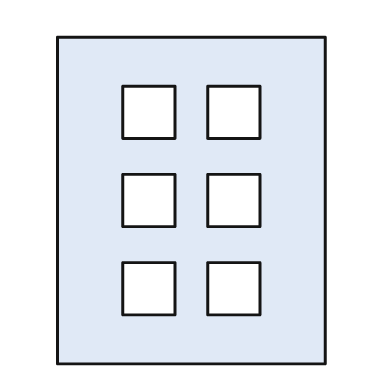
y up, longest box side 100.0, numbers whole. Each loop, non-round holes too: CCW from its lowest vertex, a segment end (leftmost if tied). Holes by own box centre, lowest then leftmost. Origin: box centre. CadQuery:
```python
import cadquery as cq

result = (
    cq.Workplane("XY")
    .moveTo(-41.0, -50.0)
    .lineTo(41.0, -50.0)
    .lineTo(41.0, 50.0)
    .lineTo(-41.0, 50.0)
    .close()
    .moveTo(-21.0, -35.0)
    .lineTo(-5.0, -35.0)
    .lineTo(-5.0, -19.0)
    .lineTo(-21.0, -19.0)
    .close()
    .moveTo(5.0, -35.0)
    .lineTo(21.0, -35.0)
    .lineTo(21.0, -19.0)
    .lineTo(5.0, -19.0)
    .close()
    .moveTo(-21.0, -8.0)
    .lineTo(-5.0, -8.0)
    .lineTo(-5.0, 8.0)
    .lineTo(-21.0, 8.0)
    .close()
    .moveTo(5.0, -8.0)
    .lineTo(21.0, -8.0)
    .lineTo(21.0, 8.0)
    .lineTo(5.0, 8.0)
    .close()
    .moveTo(-21.0, 19.0)
    .lineTo(-5.0, 19.0)
    .lineTo(-5.0, 35.0)
    .lineTo(-21.0, 35.0)
    .close()
    .moveTo(5.0, 19.0)
    .lineTo(21.0, 19.0)
    .lineTo(21.0, 35.0)
    .lineTo(5.0, 35.0)
    .close()
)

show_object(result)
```